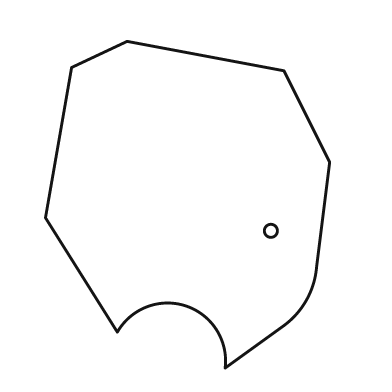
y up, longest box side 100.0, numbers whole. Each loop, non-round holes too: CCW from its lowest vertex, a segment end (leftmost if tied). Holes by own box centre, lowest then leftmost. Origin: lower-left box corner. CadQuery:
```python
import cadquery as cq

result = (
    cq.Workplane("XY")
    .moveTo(55.0, 0.0)
    .lineTo(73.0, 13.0)
    .threePointArc((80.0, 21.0), (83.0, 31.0))
    .lineTo(87.0, 63.0)
    .lineTo(73.0, 91.0)
    .lineTo(25.0, 100.0)
    .lineTo(8.0, 92.0)
    .lineTo(0.0, 46.0)
    .lineTo(22.0, 11.0)
    .threePointArc((43.0, 19.0), (55.0, 0.0))
    .close()
    .moveTo(69.0, 42.0)
    .circle(2.0)
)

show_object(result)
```